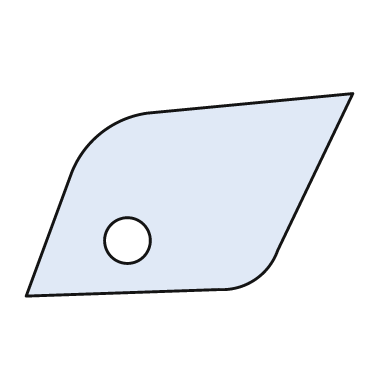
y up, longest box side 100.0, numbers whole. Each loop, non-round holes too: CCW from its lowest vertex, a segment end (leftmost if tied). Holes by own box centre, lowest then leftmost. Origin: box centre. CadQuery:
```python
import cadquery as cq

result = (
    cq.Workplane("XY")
    .moveTo(-50.0, -31.0)
    .lineTo(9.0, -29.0)
    .threePointArc((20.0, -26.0), (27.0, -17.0))
    .lineTo(50.0, 31.0)
    .lineTo(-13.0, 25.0)
    .threePointArc((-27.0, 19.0), (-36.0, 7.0))
    .close()
    .moveTo(-19.0, -14.0)
    .circle(7.0)
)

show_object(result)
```